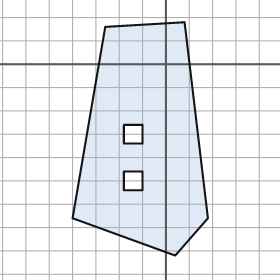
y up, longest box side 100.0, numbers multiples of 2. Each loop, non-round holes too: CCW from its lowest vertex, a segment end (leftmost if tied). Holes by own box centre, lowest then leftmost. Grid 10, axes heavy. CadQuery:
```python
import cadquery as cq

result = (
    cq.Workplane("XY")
    .moveTo(4.0, -82.0)
    .lineTo(18.0, -66.0)
    .lineTo(8.0, 18.0)
    .lineTo(-26.0, 16.0)
    .lineTo(-40.0, -66.0)
    .close()
    .moveTo(-18.0, -54.0)
    .lineTo(-10.0, -54.0)
    .lineTo(-10.0, -46.0)
    .lineTo(-18.0, -46.0)
    .close()
    .moveTo(-18.0, -34.0)
    .lineTo(-10.0, -34.0)
    .lineTo(-10.0, -26.0)
    .lineTo(-18.0, -26.0)
    .close()
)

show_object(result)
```